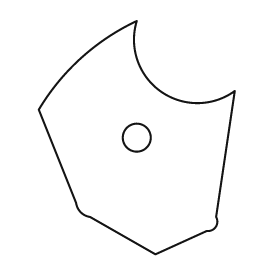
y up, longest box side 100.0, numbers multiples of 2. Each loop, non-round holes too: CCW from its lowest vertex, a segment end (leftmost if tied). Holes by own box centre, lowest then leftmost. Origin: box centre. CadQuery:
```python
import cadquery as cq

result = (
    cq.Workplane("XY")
    .moveTo(8.0, -50.0)
    .lineTo(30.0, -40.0)
    .threePointArc((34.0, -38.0), (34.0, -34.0))
    .lineTo(42.0, 20.0)
    .threePointArc((10.0, 20.0), (0.0, 50.0))
    .threePointArc((-24.0, 34.0), (-42.0, 12.0))
    .lineTo(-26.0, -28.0)
    .threePointArc((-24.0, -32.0), (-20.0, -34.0))
    .close()
    .moveTo(0.0, 0.0)
    .circle(6.0)
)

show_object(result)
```